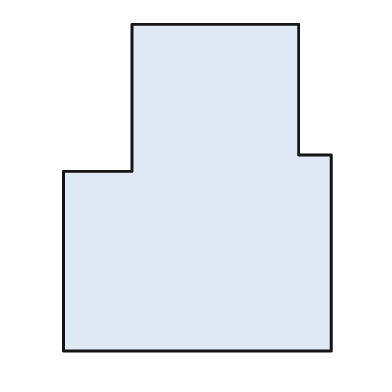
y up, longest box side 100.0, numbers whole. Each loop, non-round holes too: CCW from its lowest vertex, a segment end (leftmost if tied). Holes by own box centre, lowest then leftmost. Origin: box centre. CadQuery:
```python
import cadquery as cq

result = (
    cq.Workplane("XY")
    .moveTo(-41.0, -50.0)
    .lineTo(41.0, -50.0)
    .lineTo(41.0, 10.0)
    .lineTo(31.0, 10.0)
    .lineTo(31.0, 50.0)
    .lineTo(-20.0, 50.0)
    .lineTo(-20.0, 5.0)
    .lineTo(-41.0, 5.0)
    .close()
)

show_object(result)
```